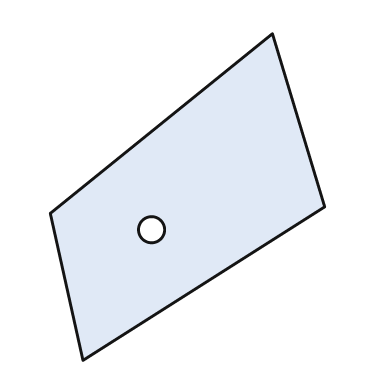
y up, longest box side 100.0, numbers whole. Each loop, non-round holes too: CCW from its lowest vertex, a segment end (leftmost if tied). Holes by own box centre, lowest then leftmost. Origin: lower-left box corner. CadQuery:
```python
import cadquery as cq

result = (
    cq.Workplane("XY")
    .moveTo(10.0, 0.0)
    .lineTo(84.0, 47.0)
    .lineTo(68.0, 100.0)
    .lineTo(0.0, 45.0)
    .close()
    .moveTo(31.0, 40.0)
    .circle(4.0)
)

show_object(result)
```